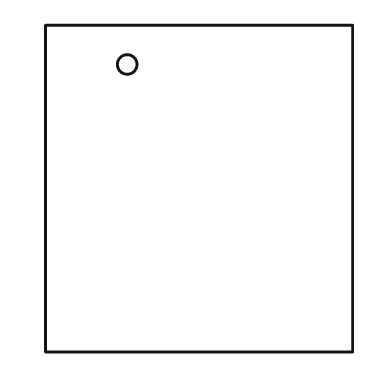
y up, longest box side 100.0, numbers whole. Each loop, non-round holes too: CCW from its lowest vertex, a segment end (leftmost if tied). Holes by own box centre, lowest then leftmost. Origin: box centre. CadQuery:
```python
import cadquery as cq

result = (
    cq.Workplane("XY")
    .moveTo(-47.0, -50.0)
    .lineTo(47.0, -50.0)
    .lineTo(47.0, 50.0)
    .lineTo(-47.0, 50.0)
    .close()
    .moveTo(-22.0, 38.0)
    .circle(3.0)
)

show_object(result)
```